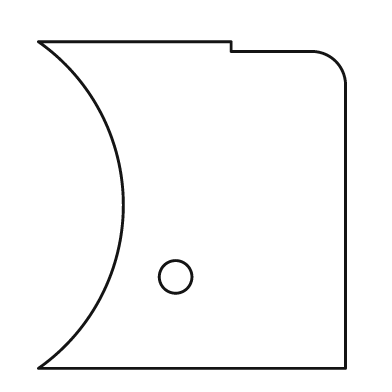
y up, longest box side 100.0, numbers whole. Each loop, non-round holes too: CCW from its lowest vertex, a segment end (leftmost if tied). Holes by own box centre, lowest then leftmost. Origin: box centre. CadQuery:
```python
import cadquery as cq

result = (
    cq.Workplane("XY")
    .moveTo(-47.0, -50.0)
    .lineTo(47.0, -50.0)
    .lineTo(47.0, 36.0)
    .threePointArc((44.0, 44.0), (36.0, 47.0))
    .lineTo(12.0, 47.0)
    .lineTo(12.0, 50.0)
    .lineTo(-47.0, 50.0)
    .threePointArc((-21.0, 0.0), (-47.0, -50.0))
    .close()
    .moveTo(-5.0, -22.0)
    .circle(5.0)
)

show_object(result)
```